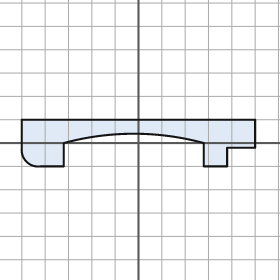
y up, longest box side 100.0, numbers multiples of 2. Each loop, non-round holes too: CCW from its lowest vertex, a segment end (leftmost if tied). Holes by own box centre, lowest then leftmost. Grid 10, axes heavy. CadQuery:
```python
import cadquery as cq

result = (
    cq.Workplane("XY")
    .moveTo(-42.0, -10.0)
    .lineTo(-32.0, -10.0)
    .lineTo(-32.0, 0.0)
    .threePointArc((-2.0, 4.0), (28.0, 0.0))
    .lineTo(28.0, -10.0)
    .lineTo(38.0, -10.0)
    .lineTo(38.0, -2.0)
    .lineTo(50.0, -2.0)
    .lineTo(50.0, 10.0)
    .lineTo(-50.0, 10.0)
    .lineTo(-50.0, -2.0)
    .threePointArc((-48.0, -8.0), (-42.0, -10.0))
    .close()
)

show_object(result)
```